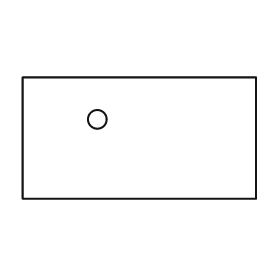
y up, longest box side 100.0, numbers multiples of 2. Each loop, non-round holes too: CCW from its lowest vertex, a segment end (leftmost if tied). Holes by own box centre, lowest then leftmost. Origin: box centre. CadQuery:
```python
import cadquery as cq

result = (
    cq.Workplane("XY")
    .moveTo(-50.0, -26.0)
    .lineTo(50.0, -26.0)
    .lineTo(50.0, 26.0)
    .lineTo(-50.0, 26.0)
    .close()
    .moveTo(-18.0, 8.0)
    .circle(4.0)
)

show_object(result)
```